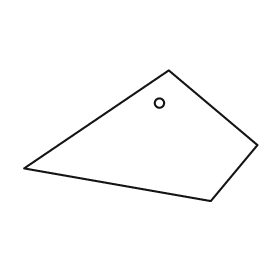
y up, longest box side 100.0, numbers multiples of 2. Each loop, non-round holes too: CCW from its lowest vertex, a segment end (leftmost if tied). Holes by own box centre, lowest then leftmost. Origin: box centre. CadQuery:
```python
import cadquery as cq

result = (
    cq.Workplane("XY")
    .moveTo(30.0, -28.0)
    .lineTo(50.0, -4.0)
    .lineTo(12.0, 28.0)
    .lineTo(-50.0, -14.0)
    .close()
    .moveTo(8.0, 14.0)
    .circle(2.0)
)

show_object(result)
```